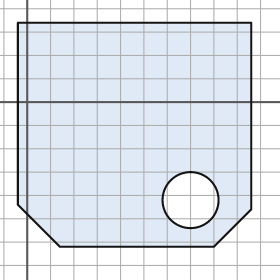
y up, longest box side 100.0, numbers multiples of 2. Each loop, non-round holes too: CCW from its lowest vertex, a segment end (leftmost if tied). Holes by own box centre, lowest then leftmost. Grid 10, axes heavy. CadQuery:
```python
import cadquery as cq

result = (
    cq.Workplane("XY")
    .moveTo(14.0, -62.0)
    .lineTo(80.0, -62.0)
    .lineTo(96.0, -46.0)
    .lineTo(96.0, 34.0)
    .lineTo(-4.0, 34.0)
    .lineTo(-4.0, -44.0)
    .close()
    .moveTo(70.0, -42.0)
    .circle(12.0)
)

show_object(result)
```